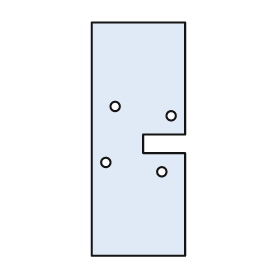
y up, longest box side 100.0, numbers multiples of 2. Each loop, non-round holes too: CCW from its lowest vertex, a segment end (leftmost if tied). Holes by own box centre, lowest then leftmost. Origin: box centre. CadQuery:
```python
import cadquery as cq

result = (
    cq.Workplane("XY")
    .moveTo(-20.0, -50.0)
    .lineTo(20.0, -50.0)
    .lineTo(20.0, -6.0)
    .lineTo(2.0, -6.0)
    .lineTo(2.0, 2.0)
    .lineTo(20.0, 2.0)
    .lineTo(20.0, 50.0)
    .lineTo(-20.0, 50.0)
    .close()
    .moveTo(10.0, -14.0)
    .circle(2.0)
    .moveTo(-14.0, -10.0)
    .circle(2.0)
    .moveTo(14.0, 10.0)
    .circle(2.0)
    .moveTo(-10.0, 14.0)
    .circle(2.0)
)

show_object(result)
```